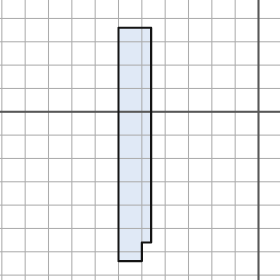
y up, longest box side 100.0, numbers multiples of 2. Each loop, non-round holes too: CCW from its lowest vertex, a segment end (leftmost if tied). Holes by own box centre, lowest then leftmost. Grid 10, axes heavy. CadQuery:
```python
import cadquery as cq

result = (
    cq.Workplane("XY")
    .moveTo(-60.0, -64.0)
    .lineTo(-50.0, -64.0)
    .lineTo(-50.0, -56.0)
    .lineTo(-46.0, -56.0)
    .lineTo(-46.0, 36.0)
    .lineTo(-60.0, 36.0)
    .close()
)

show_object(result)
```